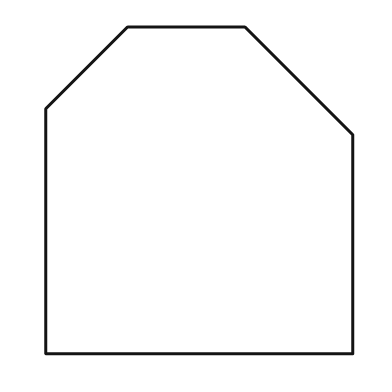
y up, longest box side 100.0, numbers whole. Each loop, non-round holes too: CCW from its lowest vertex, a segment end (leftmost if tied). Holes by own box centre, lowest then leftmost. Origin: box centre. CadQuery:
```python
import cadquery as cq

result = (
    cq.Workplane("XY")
    .moveTo(-47.0, -50.0)
    .lineTo(47.0, -50.0)
    .lineTo(47.0, 17.0)
    .lineTo(14.0, 50.0)
    .lineTo(-22.0, 50.0)
    .lineTo(-47.0, 25.0)
    .close()
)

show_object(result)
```